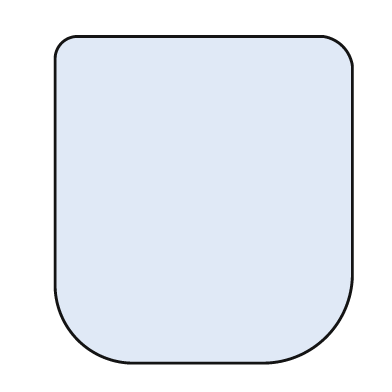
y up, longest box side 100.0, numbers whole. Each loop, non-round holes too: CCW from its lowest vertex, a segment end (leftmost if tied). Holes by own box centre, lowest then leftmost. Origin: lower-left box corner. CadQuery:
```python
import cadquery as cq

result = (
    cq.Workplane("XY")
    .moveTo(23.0, 0.0)
    .lineTo(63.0, 0.0)
    .threePointArc((83.0, 8.0), (91.0, 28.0))
    .lineTo(91.0, 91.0)
    .threePointArc((88.0, 97.0), (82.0, 100.0))
    .lineTo(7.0, 100.0)
    .threePointArc((2.0, 98.0), (0.0, 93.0))
    .lineTo(0.0, 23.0)
    .threePointArc((7.0, 7.0), (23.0, 0.0))
    .close()
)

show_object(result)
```